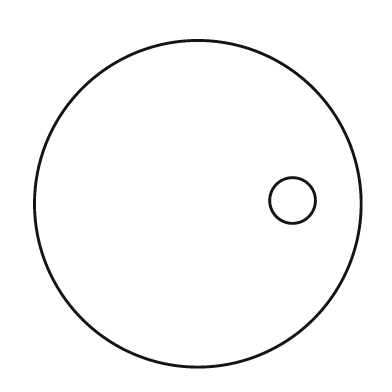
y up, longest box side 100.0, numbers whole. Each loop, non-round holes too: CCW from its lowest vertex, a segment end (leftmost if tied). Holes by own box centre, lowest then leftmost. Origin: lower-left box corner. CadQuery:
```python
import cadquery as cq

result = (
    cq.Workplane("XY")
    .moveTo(50.0, 50.0)
    .circle(50.0)
    .moveTo(79.0, 51.0)
    .circle(7.0)
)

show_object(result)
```